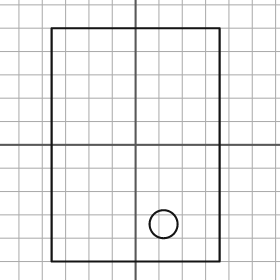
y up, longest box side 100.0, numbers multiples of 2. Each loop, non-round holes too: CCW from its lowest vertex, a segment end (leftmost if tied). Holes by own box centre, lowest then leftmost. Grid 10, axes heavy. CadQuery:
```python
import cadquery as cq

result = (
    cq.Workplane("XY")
    .moveTo(-36.0, -50.0)
    .lineTo(36.0, -50.0)
    .lineTo(36.0, 50.0)
    .lineTo(-36.0, 50.0)
    .close()
    .moveTo(12.0, -34.0)
    .circle(6.0)
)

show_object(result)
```